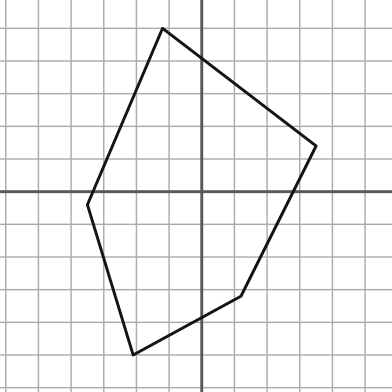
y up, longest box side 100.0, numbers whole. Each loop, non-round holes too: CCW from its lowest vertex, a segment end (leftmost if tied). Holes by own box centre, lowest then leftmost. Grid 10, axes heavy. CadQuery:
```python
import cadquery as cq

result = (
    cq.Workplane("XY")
    .moveTo(-21.0, -50.0)
    .lineTo(12.0, -32.0)
    .lineTo(35.0, 14.0)
    .lineTo(-12.0, 50.0)
    .lineTo(-35.0, -4.0)
    .close()
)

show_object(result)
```